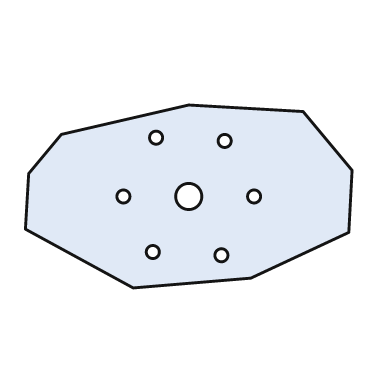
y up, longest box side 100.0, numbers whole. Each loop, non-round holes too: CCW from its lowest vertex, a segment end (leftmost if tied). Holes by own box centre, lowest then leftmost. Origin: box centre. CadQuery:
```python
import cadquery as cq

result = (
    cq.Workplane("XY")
    .moveTo(-17.0, -28.0)
    .lineTo(19.0, -25.0)
    .lineTo(49.0, -11.0)
    .lineTo(50.0, 8.0)
    .lineTo(35.0, 26.0)
    .lineTo(0.0, 28.0)
    .lineTo(-39.0, 19.0)
    .lineTo(-49.0, 7.0)
    .lineTo(-50.0, -10.0)
    .close()
    .moveTo(10.0, -18.0)
    .circle(2.0)
    .moveTo(-11.0, -17.0)
    .circle(2.0)
    .moveTo(-20.0, 0.0)
    .circle(2.0)
    .moveTo(0.0, 0.0)
    .circle(4.0)
    .moveTo(20.0, 0.0)
    .circle(2.0)
    .moveTo(11.0, 17.0)
    .circle(2.0)
    .moveTo(-10.0, 18.0)
    .circle(2.0)
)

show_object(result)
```